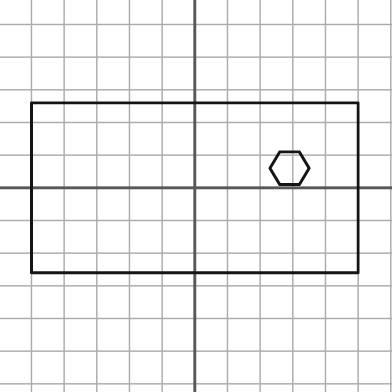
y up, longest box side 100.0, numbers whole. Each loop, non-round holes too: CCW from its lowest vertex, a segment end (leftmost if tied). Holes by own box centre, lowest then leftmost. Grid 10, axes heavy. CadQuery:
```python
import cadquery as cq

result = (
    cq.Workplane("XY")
    .moveTo(-50.0, -26.0)
    .lineTo(50.0, -26.0)
    .lineTo(50.0, 26.0)
    .lineTo(-50.0, 26.0)
    .close()
    .moveTo(26.0, 1.0)
    .lineTo(32.0, 1.0)
    .lineTo(35.0, 6.0)
    .lineTo(32.0, 11.0)
    .lineTo(26.0, 11.0)
    .lineTo(23.0, 6.0)
    .close()
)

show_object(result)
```